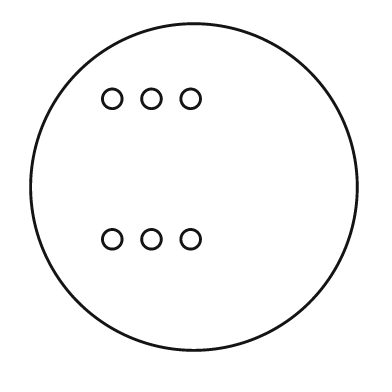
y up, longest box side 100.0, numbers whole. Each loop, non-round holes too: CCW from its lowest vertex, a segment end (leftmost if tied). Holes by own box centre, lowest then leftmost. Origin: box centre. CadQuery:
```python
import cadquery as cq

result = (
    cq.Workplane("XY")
    .moveTo(0.0, 0.0)
    .circle(50.0)
    .moveTo(-25.0, -16.0)
    .circle(3.0)
    .moveTo(-13.0, -16.0)
    .circle(3.0)
    .moveTo(-1.0, -16.0)
    .circle(3.0)
    .moveTo(-25.0, 27.0)
    .circle(3.0)
    .moveTo(-13.0, 27.0)
    .circle(3.0)
    .moveTo(-1.0, 27.0)
    .circle(3.0)
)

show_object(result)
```